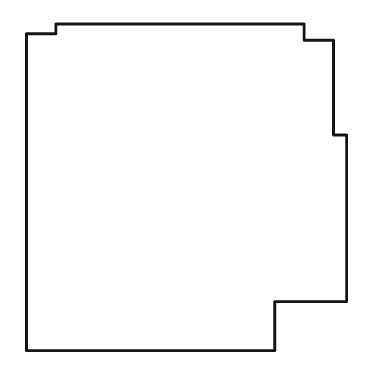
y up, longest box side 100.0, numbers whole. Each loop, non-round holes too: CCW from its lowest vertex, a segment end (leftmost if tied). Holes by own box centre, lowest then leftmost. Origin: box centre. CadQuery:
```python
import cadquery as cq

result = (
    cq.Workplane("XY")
    .moveTo(-49.0, -50.0)
    .lineTo(27.0, -50.0)
    .lineTo(27.0, -35.0)
    .lineTo(49.0, -35.0)
    .lineTo(49.0, 16.0)
    .lineTo(45.0, 16.0)
    .lineTo(45.0, 45.0)
    .lineTo(36.0, 45.0)
    .lineTo(36.0, 50.0)
    .lineTo(-40.0, 50.0)
    .lineTo(-40.0, 47.0)
    .lineTo(-49.0, 47.0)
    .close()
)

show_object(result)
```